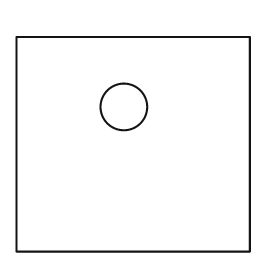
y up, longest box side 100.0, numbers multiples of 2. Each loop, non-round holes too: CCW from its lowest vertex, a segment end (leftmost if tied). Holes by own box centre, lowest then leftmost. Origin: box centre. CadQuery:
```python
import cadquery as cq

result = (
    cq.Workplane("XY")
    .moveTo(-50.0, -46.0)
    .lineTo(50.0, -46.0)
    .lineTo(50.0, 46.0)
    .lineTo(-50.0, 46.0)
    .close()
    .moveTo(-4.0, 16.0)
    .circle(10.0)
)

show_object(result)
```